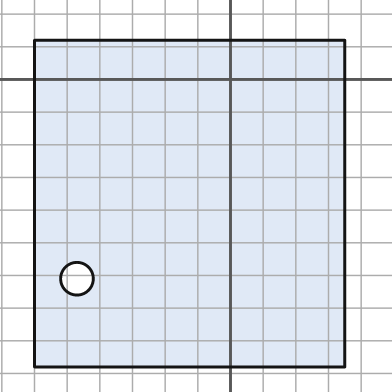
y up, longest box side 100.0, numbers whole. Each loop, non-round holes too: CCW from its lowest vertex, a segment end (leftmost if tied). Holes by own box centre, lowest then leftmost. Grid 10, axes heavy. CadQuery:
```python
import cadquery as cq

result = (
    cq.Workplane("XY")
    .moveTo(-60.0, -88.0)
    .lineTo(35.0, -88.0)
    .lineTo(35.0, 12.0)
    .lineTo(-60.0, 12.0)
    .close()
    .moveTo(-47.0, -61.0)
    .circle(5.0)
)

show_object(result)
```